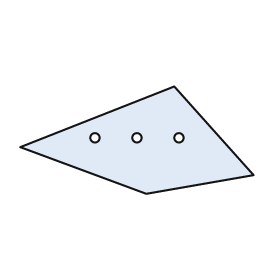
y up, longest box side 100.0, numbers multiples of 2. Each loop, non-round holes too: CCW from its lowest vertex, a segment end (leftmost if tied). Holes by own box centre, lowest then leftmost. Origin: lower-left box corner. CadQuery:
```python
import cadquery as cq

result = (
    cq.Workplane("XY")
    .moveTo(54.0, 0.0)
    .lineTo(100.0, 8.0)
    .lineTo(66.0, 46.0)
    .lineTo(0.0, 20.0)
    .close()
    .moveTo(32.0, 24.0)
    .circle(2.0)
    .moveTo(50.0, 24.0)
    .circle(2.0)
    .moveTo(68.0, 24.0)
    .circle(2.0)
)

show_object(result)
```